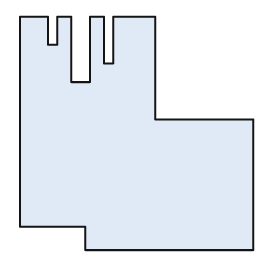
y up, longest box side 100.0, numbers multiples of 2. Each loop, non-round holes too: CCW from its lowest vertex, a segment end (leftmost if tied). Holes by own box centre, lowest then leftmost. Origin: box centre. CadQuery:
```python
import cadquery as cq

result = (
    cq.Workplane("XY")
    .moveTo(-22.0, -50.0)
    .lineTo(50.0, -50.0)
    .lineTo(50.0, 6.0)
    .lineTo(8.0, 6.0)
    .lineTo(8.0, 50.0)
    .lineTo(-10.0, 50.0)
    .lineTo(-10.0, 30.0)
    .lineTo(-14.0, 30.0)
    .lineTo(-14.0, 50.0)
    .lineTo(-20.0, 50.0)
    .lineTo(-20.0, 22.0)
    .lineTo(-28.0, 22.0)
    .lineTo(-28.0, 50.0)
    .lineTo(-34.0, 50.0)
    .lineTo(-34.0, 38.0)
    .lineTo(-38.0, 38.0)
    .lineTo(-38.0, 50.0)
    .lineTo(-50.0, 50.0)
    .lineTo(-50.0, -40.0)
    .lineTo(-22.0, -40.0)
    .close()
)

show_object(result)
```